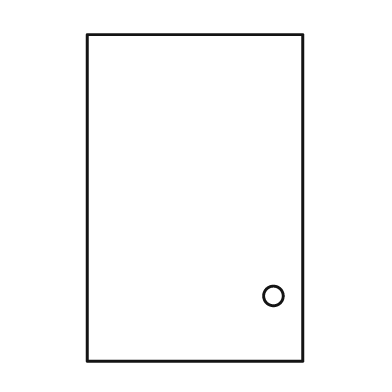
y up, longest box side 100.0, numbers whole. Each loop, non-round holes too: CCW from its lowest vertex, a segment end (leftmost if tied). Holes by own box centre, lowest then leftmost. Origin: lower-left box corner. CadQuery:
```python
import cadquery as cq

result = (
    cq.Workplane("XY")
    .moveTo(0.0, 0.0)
    .lineTo(66.0, 0.0)
    .lineTo(66.0, 100.0)
    .lineTo(0.0, 100.0)
    .close()
    .moveTo(57.0, 20.0)
    .circle(3.0)
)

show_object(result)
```